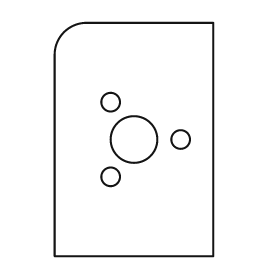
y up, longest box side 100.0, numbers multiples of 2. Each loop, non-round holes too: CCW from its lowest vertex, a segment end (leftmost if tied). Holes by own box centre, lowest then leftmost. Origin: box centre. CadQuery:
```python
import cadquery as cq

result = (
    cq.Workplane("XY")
    .moveTo(-34.0, -50.0)
    .lineTo(34.0, -50.0)
    .lineTo(34.0, 50.0)
    .lineTo(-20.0, 50.0)
    .threePointArc((-30.0, 46.0), (-34.0, 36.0))
    .close()
    .moveTo(-10.0, -16.0)
    .circle(4.0)
    .moveTo(0.0, 0.0)
    .circle(10.0)
    .moveTo(20.0, 0.0)
    .circle(4.0)
    .moveTo(-10.0, 16.0)
    .circle(4.0)
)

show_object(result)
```